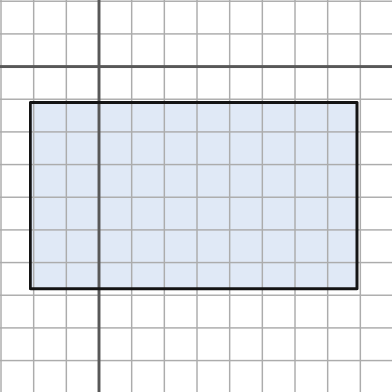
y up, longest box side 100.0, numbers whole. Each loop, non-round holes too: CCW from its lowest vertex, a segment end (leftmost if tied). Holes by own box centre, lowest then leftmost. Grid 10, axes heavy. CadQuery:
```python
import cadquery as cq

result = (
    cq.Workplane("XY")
    .moveTo(-21.0, -68.0)
    .lineTo(79.0, -68.0)
    .lineTo(79.0, -11.0)
    .lineTo(-21.0, -11.0)
    .close()
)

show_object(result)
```